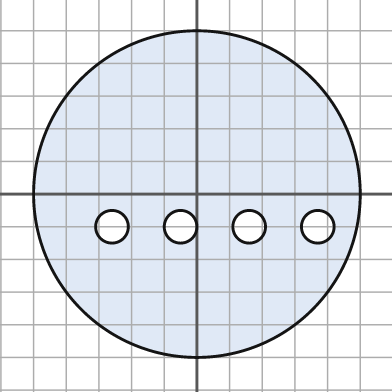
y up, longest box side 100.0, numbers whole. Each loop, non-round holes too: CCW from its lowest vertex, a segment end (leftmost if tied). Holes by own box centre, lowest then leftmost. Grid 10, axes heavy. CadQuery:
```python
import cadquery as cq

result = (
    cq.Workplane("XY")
    .moveTo(0.0, 0.0)
    .circle(50.0)
    .moveTo(-26.0, -10.0)
    .circle(5.0)
    .moveTo(-5.0, -10.0)
    .circle(5.0)
    .moveTo(16.0, -10.0)
    .circle(5.0)
    .moveTo(37.0, -10.0)
    .circle(5.0)
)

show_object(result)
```